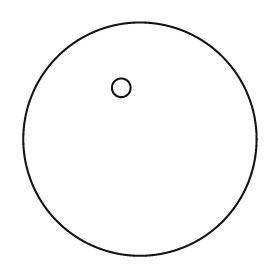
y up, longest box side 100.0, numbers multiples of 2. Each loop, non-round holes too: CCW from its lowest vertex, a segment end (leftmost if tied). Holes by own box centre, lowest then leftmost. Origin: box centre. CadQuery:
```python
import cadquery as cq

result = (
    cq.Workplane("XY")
    .moveTo(0.0, 0.0)
    .circle(50.0)
    .moveTo(-8.0, 22.0)
    .circle(4.0)
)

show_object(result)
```